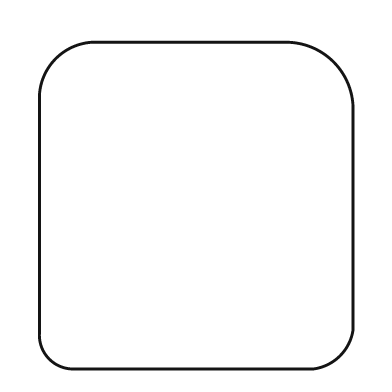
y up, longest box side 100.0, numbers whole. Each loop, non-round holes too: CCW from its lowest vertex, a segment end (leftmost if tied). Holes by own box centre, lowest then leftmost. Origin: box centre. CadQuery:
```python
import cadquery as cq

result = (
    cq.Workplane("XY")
    .moveTo(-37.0, -50.0)
    .lineTo(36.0, -50.0)
    .threePointArc((44.0, -46.0), (48.0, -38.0))
    .lineTo(48.0, 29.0)
    .threePointArc((42.0, 44.0), (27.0, 50.0))
    .lineTo(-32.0, 50.0)
    .threePointArc((-43.0, 45.0), (-48.0, 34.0))
    .lineTo(-48.0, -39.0)
    .threePointArc((-45.0, -47.0), (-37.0, -50.0))
    .close()
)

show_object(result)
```